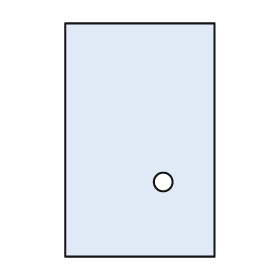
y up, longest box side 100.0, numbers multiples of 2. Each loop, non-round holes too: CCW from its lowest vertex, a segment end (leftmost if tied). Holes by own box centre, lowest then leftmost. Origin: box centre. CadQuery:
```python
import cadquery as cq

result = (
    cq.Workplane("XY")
    .moveTo(-32.0, -50.0)
    .lineTo(32.0, -50.0)
    .lineTo(32.0, 50.0)
    .lineTo(-32.0, 50.0)
    .close()
    .moveTo(10.0, -18.0)
    .circle(4.0)
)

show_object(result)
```